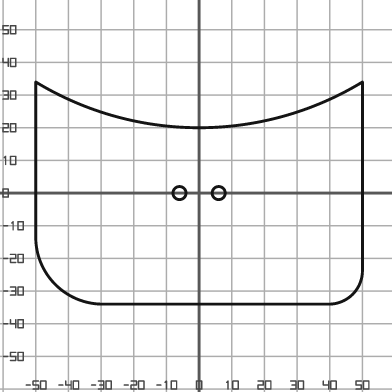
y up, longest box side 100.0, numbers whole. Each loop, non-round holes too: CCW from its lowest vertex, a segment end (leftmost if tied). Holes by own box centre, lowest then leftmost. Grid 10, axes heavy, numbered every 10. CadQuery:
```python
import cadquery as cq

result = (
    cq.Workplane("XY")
    .moveTo(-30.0, -34.0)
    .lineTo(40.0, -34.0)
    .threePointArc((47.0, -31.0), (50.0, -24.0))
    .lineTo(50.0, 34.0)
    .threePointArc((0.0, 20.0), (-50.0, 34.0))
    .lineTo(-50.0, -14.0)
    .threePointArc((-44.0, -28.0), (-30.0, -34.0))
    .close()
    .moveTo(-6.0, 0.0)
    .circle(2.0)
    .moveTo(6.0, 0.0)
    .circle(2.0)
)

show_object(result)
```